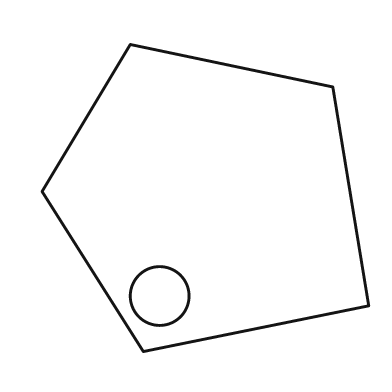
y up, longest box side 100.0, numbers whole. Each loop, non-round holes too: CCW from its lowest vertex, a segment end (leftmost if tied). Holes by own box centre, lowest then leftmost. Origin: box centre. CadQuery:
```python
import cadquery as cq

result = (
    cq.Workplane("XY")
    .moveTo(-19.0, -47.0)
    .lineTo(50.0, -33.0)
    .lineTo(39.0, 34.0)
    .lineTo(-23.0, 47.0)
    .lineTo(-50.0, 2.0)
    .close()
    .moveTo(-14.0, -30.0)
    .circle(9.0)
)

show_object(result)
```